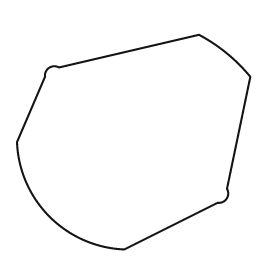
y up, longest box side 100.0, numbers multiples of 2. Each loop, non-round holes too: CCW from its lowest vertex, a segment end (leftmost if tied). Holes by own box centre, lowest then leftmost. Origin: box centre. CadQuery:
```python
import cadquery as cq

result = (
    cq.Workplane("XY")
    .moveTo(-4.0, -46.0)
    .lineTo(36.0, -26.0)
    .threePointArc((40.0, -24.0), (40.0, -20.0))
    .lineTo(50.0, 28.0)
    .threePointArc((40.0, 38.0), (28.0, 46.0))
    .lineTo(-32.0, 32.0)
    .threePointArc((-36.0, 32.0), (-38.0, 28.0))
    .lineTo(-50.0, 0.0)
    .threePointArc((-36.0, -32.0), (-4.0, -46.0))
    .close()
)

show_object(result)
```